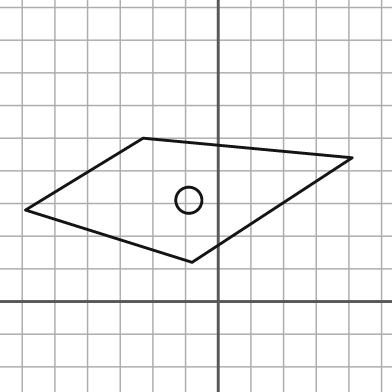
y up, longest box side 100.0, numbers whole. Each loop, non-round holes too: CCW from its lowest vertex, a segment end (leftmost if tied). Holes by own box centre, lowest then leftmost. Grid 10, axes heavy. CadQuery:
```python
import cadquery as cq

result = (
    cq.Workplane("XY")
    .moveTo(-8.0, 12.0)
    .lineTo(41.0, 44.0)
    .lineTo(-23.0, 50.0)
    .lineTo(-59.0, 28.0)
    .close()
    .moveTo(-9.0, 31.0)
    .circle(4.0)
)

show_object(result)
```